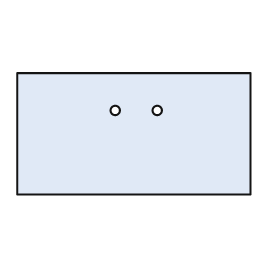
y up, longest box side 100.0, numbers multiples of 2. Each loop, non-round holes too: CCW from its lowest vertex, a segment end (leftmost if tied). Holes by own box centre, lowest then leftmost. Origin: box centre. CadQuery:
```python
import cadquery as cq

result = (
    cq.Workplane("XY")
    .moveTo(-50.0, -26.0)
    .lineTo(50.0, -26.0)
    .lineTo(50.0, 26.0)
    .lineTo(-50.0, 26.0)
    .close()
    .moveTo(-8.0, 10.0)
    .circle(2.0)
    .moveTo(10.0, 10.0)
    .circle(2.0)
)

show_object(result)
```